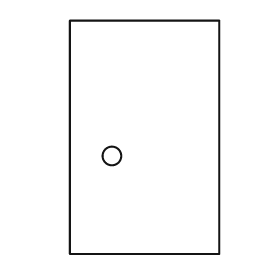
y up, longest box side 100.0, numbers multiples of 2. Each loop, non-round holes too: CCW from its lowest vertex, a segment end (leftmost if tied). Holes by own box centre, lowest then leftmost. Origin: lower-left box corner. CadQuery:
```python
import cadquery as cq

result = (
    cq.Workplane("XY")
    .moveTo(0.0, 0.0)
    .lineTo(64.0, 0.0)
    .lineTo(64.0, 100.0)
    .lineTo(0.0, 100.0)
    .close()
    .moveTo(18.0, 42.0)
    .circle(4.0)
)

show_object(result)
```